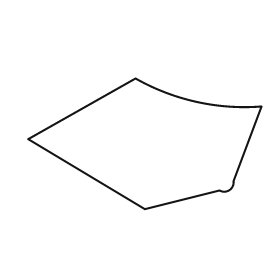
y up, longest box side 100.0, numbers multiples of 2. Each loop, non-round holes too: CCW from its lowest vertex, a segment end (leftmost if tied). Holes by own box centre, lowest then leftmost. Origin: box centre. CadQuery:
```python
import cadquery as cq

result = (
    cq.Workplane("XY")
    .moveTo(0.0, -28.0)
    .lineTo(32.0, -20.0)
    .threePointArc((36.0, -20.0), (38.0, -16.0))
    .lineTo(50.0, 16.0)
    .threePointArc((22.0, 18.0), (-4.0, 28.0))
    .lineTo(-50.0, 2.0)
    .close()
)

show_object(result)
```